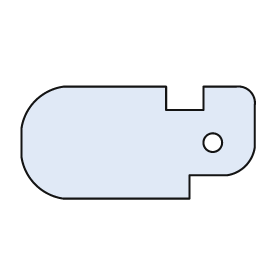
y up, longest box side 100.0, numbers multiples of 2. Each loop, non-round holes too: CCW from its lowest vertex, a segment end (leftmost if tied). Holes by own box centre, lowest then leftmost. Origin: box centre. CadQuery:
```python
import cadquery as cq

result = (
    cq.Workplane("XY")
    .moveTo(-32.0, -24.0)
    .lineTo(22.0, -24.0)
    .lineTo(22.0, -14.0)
    .lineTo(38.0, -14.0)
    .threePointArc((46.0, -10.0), (50.0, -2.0))
    .lineTo(50.0, 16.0)
    .threePointArc((48.0, 22.0), (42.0, 24.0))
    .lineTo(28.0, 24.0)
    .lineTo(28.0, 14.0)
    .lineTo(12.0, 14.0)
    .lineTo(12.0, 24.0)
    .lineTo(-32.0, 24.0)
    .threePointArc((-44.0, 18.0), (-50.0, 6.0))
    .lineTo(-50.0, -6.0)
    .threePointArc((-44.0, -18.0), (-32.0, -24.0))
    .close()
    .moveTo(32.0, 0.0)
    .circle(4.0)
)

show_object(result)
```